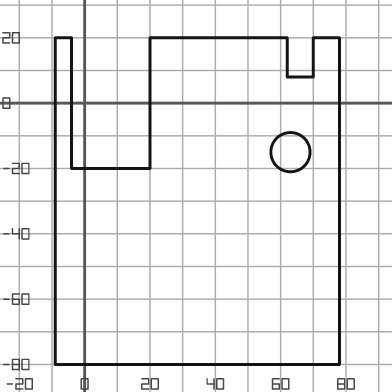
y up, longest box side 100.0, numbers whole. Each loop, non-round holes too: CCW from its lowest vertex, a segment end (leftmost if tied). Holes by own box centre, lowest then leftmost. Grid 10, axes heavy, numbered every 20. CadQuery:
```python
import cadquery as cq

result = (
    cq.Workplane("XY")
    .moveTo(-9.0, -80.0)
    .lineTo(78.0, -80.0)
    .lineTo(78.0, 20.0)
    .lineTo(70.0, 20.0)
    .lineTo(70.0, 8.0)
    .lineTo(62.0, 8.0)
    .lineTo(62.0, 20.0)
    .lineTo(20.0, 20.0)
    .lineTo(20.0, -20.0)
    .lineTo(-4.0, -20.0)
    .lineTo(-4.0, 20.0)
    .lineTo(-9.0, 20.0)
    .close()
    .moveTo(63.0, -15.0)
    .circle(6.0)
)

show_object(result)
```